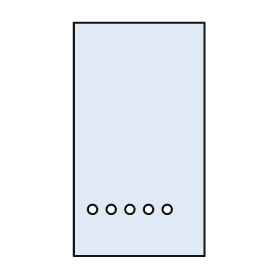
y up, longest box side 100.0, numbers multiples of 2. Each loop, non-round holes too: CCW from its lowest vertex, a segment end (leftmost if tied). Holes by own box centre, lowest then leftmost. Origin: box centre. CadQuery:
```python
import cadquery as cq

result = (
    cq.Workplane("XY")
    .moveTo(-28.0, -50.0)
    .lineTo(28.0, -50.0)
    .lineTo(28.0, 50.0)
    .lineTo(-28.0, 50.0)
    .close()
    .moveTo(-20.0, -30.0)
    .circle(2.0)
    .moveTo(-12.0, -30.0)
    .circle(2.0)
    .moveTo(-4.0, -30.0)
    .circle(2.0)
    .moveTo(4.0, -30.0)
    .circle(2.0)
    .moveTo(12.0, -30.0)
    .circle(2.0)
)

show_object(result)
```